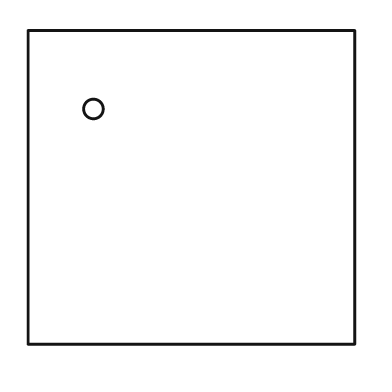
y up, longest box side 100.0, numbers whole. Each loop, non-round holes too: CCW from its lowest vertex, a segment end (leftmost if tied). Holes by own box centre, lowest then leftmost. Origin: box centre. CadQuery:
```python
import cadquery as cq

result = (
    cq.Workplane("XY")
    .moveTo(-50.0, -48.0)
    .lineTo(50.0, -48.0)
    .lineTo(50.0, 48.0)
    .lineTo(-50.0, 48.0)
    .close()
    .moveTo(-30.0, 24.0)
    .circle(3.0)
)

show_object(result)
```